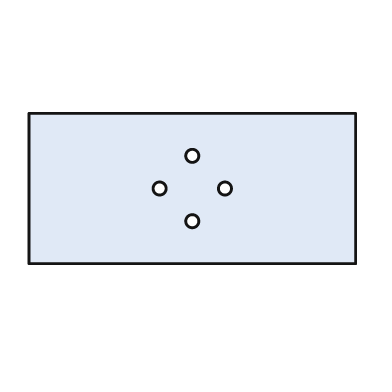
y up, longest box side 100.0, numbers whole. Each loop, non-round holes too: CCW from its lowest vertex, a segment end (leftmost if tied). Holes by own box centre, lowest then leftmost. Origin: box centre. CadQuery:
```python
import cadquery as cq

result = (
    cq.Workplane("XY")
    .moveTo(-50.0, -23.0)
    .lineTo(50.0, -23.0)
    .lineTo(50.0, 23.0)
    .lineTo(-50.0, 23.0)
    .close()
    .moveTo(0.0, -10.0)
    .circle(2.0)
    .moveTo(-10.0, 0.0)
    .circle(2.0)
    .moveTo(10.0, 0.0)
    .circle(2.0)
    .moveTo(0.0, 10.0)
    .circle(2.0)
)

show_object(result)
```